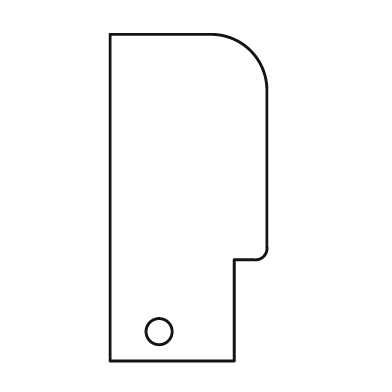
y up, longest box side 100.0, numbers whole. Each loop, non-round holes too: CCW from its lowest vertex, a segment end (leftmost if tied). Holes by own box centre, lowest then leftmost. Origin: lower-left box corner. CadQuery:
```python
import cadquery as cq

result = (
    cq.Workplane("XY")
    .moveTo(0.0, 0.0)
    .lineTo(38.0, 0.0)
    .lineTo(38.0, 31.0)
    .lineTo(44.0, 31.0)
    .threePointArc((47.0, 32.0), (48.0, 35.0))
    .lineTo(48.0, 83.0)
    .threePointArc((43.0, 95.0), (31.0, 100.0))
    .lineTo(0.0, 100.0)
    .close()
    .moveTo(15.0, 9.0)
    .circle(4.0)
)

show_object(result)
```